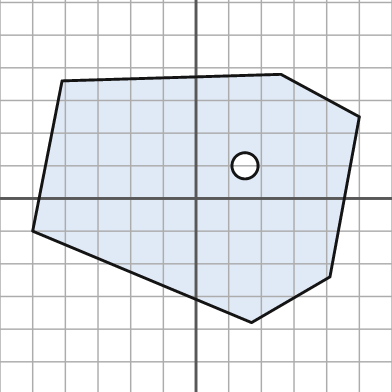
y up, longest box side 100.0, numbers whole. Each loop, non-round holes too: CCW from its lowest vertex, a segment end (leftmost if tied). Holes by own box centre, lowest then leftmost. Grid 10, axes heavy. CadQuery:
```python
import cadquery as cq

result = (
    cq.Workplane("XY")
    .moveTo(17.0, -38.0)
    .lineTo(41.0, -24.0)
    .lineTo(50.0, 25.0)
    .lineTo(26.0, 38.0)
    .lineTo(-41.0, 36.0)
    .lineTo(-50.0, -10.0)
    .close()
    .moveTo(15.0, 10.0)
    .circle(4.0)
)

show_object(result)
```